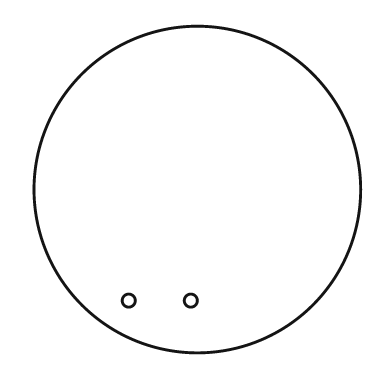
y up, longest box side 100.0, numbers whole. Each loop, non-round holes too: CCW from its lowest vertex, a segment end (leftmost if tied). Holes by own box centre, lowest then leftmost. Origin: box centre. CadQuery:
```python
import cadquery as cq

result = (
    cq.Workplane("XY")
    .moveTo(0.0, 0.0)
    .circle(50.0)
    .moveTo(-21.0, -34.0)
    .circle(2.0)
    .moveTo(-2.0, -34.0)
    .circle(2.0)
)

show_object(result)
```